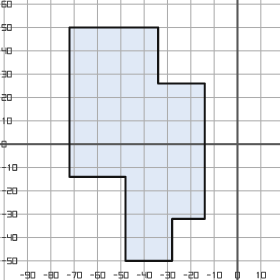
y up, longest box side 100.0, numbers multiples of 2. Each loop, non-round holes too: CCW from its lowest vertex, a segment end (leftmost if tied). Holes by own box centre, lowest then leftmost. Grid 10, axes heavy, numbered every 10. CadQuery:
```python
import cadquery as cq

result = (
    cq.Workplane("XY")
    .moveTo(-48.0, -50.0)
    .lineTo(-28.0, -50.0)
    .lineTo(-28.0, -32.0)
    .lineTo(-14.0, -32.0)
    .lineTo(-14.0, 26.0)
    .lineTo(-34.0, 26.0)
    .lineTo(-34.0, 50.0)
    .lineTo(-72.0, 50.0)
    .lineTo(-72.0, -14.0)
    .lineTo(-48.0, -14.0)
    .close()
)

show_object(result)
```